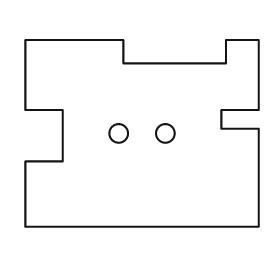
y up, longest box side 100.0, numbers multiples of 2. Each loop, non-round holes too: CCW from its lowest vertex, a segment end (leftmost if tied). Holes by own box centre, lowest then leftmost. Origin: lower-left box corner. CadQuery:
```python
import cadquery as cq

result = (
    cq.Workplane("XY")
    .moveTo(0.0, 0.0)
    .lineTo(100.0, 0.0)
    .lineTo(100.0, 42.0)
    .lineTo(84.0, 42.0)
    .lineTo(84.0, 50.0)
    .lineTo(100.0, 50.0)
    .lineTo(100.0, 80.0)
    .lineTo(86.0, 80.0)
    .lineTo(86.0, 70.0)
    .lineTo(42.0, 70.0)
    .lineTo(42.0, 80.0)
    .lineTo(0.0, 80.0)
    .lineTo(0.0, 50.0)
    .lineTo(16.0, 50.0)
    .lineTo(16.0, 28.0)
    .lineTo(0.0, 28.0)
    .close()
    .moveTo(40.0, 40.0)
    .circle(4.0)
    .moveTo(60.0, 40.0)
    .circle(4.0)
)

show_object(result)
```